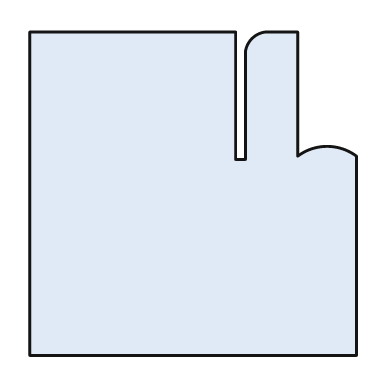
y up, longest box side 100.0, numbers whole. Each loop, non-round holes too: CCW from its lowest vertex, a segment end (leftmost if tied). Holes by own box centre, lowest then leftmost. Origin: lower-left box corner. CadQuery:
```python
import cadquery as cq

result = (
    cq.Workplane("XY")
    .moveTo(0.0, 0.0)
    .lineTo(100.0, 0.0)
    .lineTo(100.0, 61.0)
    .threePointArc((91.0, 64.0), (82.0, 61.0))
    .lineTo(82.0, 99.0)
    .lineTo(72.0, 99.0)
    .threePointArc((68.0, 97.0), (66.0, 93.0))
    .lineTo(66.0, 60.0)
    .lineTo(63.0, 60.0)
    .lineTo(63.0, 99.0)
    .lineTo(0.0, 99.0)
    .close()
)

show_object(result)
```